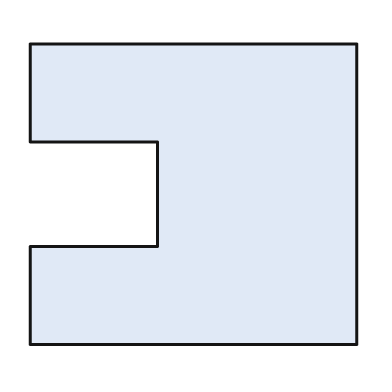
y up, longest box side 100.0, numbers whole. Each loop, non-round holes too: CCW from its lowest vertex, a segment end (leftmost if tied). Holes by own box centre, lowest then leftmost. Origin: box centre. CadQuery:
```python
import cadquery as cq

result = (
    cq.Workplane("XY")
    .moveTo(-50.0, -46.0)
    .lineTo(50.0, -46.0)
    .lineTo(50.0, 46.0)
    .lineTo(-50.0, 46.0)
    .lineTo(-50.0, 16.0)
    .lineTo(-11.0, 16.0)
    .lineTo(-11.0, -16.0)
    .lineTo(-50.0, -16.0)
    .close()
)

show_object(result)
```